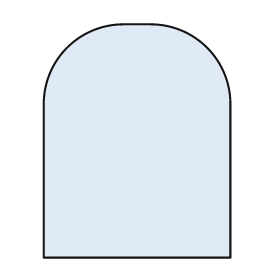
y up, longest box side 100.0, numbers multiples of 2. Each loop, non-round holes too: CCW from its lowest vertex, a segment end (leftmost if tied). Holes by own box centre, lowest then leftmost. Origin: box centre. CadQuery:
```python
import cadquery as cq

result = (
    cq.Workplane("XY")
    .moveTo(-40.0, -50.0)
    .lineTo(40.0, -50.0)
    .lineTo(40.0, 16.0)
    .threePointArc((30.0, 40.0), (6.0, 50.0))
    .lineTo(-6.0, 50.0)
    .threePointArc((-30.0, 40.0), (-40.0, 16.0))
    .close()
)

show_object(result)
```